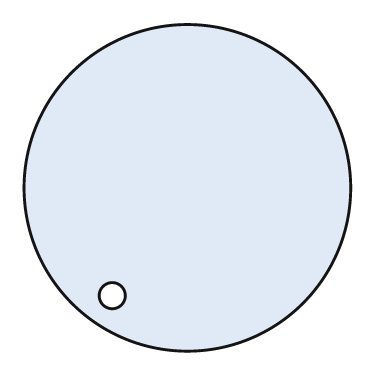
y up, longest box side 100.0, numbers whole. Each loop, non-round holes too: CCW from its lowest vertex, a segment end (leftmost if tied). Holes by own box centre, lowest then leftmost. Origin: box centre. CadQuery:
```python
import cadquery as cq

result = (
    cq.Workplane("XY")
    .moveTo(0.0, 0.0)
    .circle(50.0)
    .moveTo(-23.0, -33.0)
    .circle(4.0)
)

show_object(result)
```